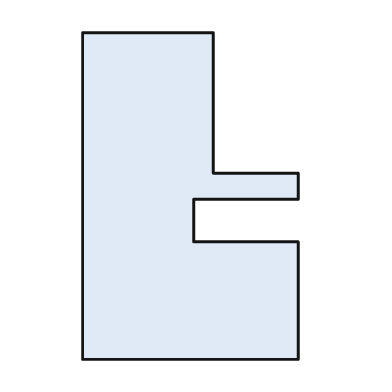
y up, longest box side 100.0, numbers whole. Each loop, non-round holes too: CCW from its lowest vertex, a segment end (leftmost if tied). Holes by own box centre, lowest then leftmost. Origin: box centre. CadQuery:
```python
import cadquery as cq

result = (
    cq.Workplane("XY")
    .moveTo(-33.0, -50.0)
    .lineTo(33.0, -50.0)
    .lineTo(33.0, -14.0)
    .lineTo(1.0, -14.0)
    .lineTo(1.0, -1.0)
    .lineTo(33.0, -1.0)
    .lineTo(33.0, 7.0)
    .lineTo(7.0, 7.0)
    .lineTo(7.0, 50.0)
    .lineTo(-33.0, 50.0)
    .close()
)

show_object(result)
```